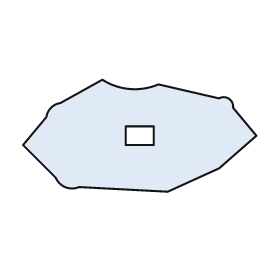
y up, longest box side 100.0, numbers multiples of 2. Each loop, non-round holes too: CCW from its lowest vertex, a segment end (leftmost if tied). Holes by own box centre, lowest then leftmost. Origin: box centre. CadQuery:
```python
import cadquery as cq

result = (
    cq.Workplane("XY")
    .moveTo(12.0, -24.0)
    .lineTo(34.0, -14.0)
    .lineTo(50.0, 0.0)
    .lineTo(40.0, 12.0)
    .threePointArc((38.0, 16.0), (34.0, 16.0))
    .lineTo(8.0, 22.0)
    .threePointArc((-4.0, 20.0), (-16.0, 24.0))
    .lineTo(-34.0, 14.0)
    .threePointArc((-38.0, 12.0), (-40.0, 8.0))
    .lineTo(-50.0, -4.0)
    .lineTo(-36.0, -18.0)
    .threePointArc((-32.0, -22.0), (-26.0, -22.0))
    .close()
    .moveTo(-6.0, -4.0)
    .lineTo(6.0, -4.0)
    .lineTo(6.0, 4.0)
    .lineTo(-6.0, 4.0)
    .close()
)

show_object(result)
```